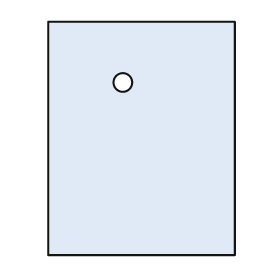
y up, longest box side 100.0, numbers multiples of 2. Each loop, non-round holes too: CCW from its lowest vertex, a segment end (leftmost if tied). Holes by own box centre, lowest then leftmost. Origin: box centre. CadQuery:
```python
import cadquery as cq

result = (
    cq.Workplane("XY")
    .moveTo(-40.0, -50.0)
    .lineTo(40.0, -50.0)
    .lineTo(40.0, 50.0)
    .lineTo(-40.0, 50.0)
    .close()
    .moveTo(-8.0, 24.0)
    .circle(4.0)
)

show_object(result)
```